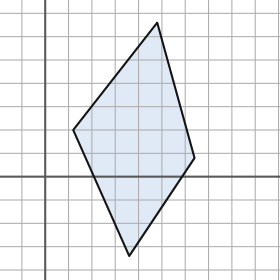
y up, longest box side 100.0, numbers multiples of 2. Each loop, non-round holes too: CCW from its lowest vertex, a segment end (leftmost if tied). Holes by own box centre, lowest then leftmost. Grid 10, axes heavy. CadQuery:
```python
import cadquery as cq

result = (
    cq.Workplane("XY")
    .moveTo(36.0, -34.0)
    .lineTo(64.0, 8.0)
    .lineTo(48.0, 66.0)
    .lineTo(12.0, 20.0)
    .close()
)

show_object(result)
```